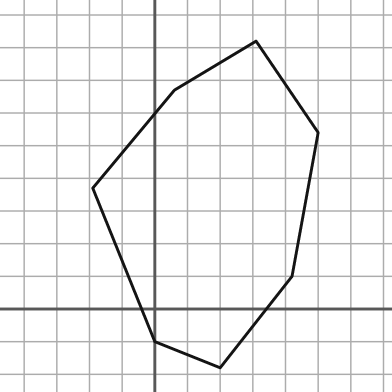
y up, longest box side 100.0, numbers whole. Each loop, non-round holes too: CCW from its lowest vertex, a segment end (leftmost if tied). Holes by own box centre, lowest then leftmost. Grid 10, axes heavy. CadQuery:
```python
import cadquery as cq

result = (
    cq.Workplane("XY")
    .moveTo(20.0, -18.0)
    .lineTo(42.0, 10.0)
    .lineTo(50.0, 54.0)
    .lineTo(31.0, 82.0)
    .lineTo(6.0, 67.0)
    .lineTo(-19.0, 37.0)
    .lineTo(0.0, -10.0)
    .close()
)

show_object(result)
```